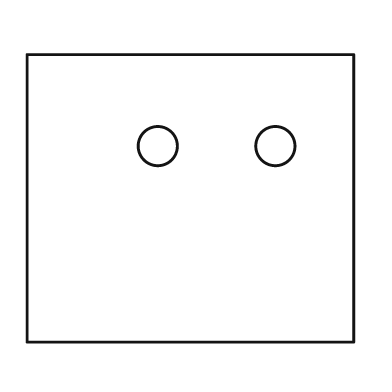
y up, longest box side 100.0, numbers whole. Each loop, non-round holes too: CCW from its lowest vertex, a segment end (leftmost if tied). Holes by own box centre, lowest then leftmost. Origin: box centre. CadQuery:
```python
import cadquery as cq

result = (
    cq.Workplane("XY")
    .moveTo(-50.0, -44.0)
    .lineTo(50.0, -44.0)
    .lineTo(50.0, 44.0)
    .lineTo(-50.0, 44.0)
    .close()
    .moveTo(-10.0, 16.0)
    .circle(6.0)
    .moveTo(26.0, 16.0)
    .circle(6.0)
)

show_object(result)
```